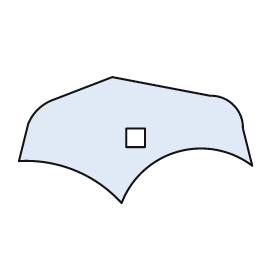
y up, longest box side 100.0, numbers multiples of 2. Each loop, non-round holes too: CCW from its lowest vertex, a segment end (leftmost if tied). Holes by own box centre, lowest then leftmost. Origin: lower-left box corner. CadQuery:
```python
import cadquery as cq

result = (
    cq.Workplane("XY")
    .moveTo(44.0, 0.0)
    .threePointArc((68.0, 22.0), (100.0, 16.0))
    .lineTo(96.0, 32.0)
    .threePointArc((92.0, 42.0), (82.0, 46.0))
    .lineTo(40.0, 54.0)
    .lineTo(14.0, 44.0)
    .threePointArc((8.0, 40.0), (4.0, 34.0))
    .lineTo(0.0, 18.0)
    .threePointArc((24.0, 14.0), (44.0, 0.0))
    .close()
    .moveTo(46.0, 24.0)
    .lineTo(54.0, 24.0)
    .lineTo(54.0, 32.0)
    .lineTo(46.0, 32.0)
    .close()
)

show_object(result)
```